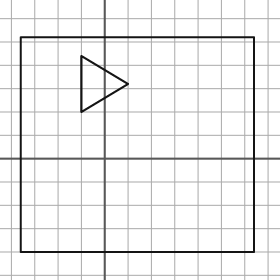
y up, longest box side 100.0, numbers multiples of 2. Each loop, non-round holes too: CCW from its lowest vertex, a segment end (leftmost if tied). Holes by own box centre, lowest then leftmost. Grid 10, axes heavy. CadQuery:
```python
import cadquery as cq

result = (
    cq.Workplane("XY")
    .moveTo(-36.0, -40.0)
    .lineTo(64.0, -40.0)
    .lineTo(64.0, 52.0)
    .lineTo(-36.0, 52.0)
    .close()
    .moveTo(-10.0, 20.0)
    .lineTo(10.0, 32.0)
    .lineTo(-10.0, 44.0)
    .close()
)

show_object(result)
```